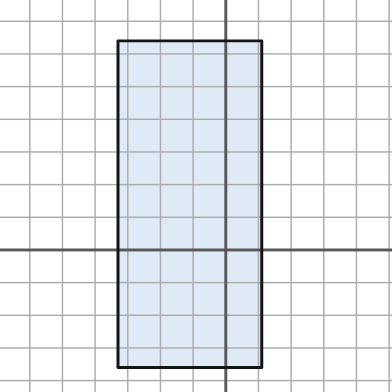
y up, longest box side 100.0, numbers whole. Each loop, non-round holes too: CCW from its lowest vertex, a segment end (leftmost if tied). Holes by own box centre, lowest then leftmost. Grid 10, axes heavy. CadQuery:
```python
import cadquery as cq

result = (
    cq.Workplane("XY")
    .moveTo(-33.0, -36.0)
    .lineTo(11.0, -36.0)
    .lineTo(11.0, 64.0)
    .lineTo(-33.0, 64.0)
    .close()
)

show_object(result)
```